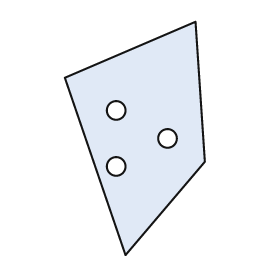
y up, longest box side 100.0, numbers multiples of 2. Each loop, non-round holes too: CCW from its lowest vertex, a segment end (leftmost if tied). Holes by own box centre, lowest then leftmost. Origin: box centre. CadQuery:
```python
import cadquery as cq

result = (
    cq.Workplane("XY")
    .moveTo(-4.0, -50.0)
    .lineTo(30.0, -10.0)
    .lineTo(26.0, 50.0)
    .lineTo(-30.0, 26.0)
    .close()
    .moveTo(-8.0, -12.0)
    .circle(4.0)
    .moveTo(14.0, 0.0)
    .circle(4.0)
    .moveTo(-8.0, 12.0)
    .circle(4.0)
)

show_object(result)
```